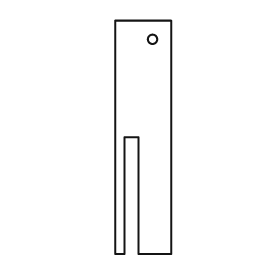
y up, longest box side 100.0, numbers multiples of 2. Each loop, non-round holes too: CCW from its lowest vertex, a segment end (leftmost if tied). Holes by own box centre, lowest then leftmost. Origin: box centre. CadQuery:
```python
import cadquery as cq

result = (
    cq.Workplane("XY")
    .moveTo(-12.0, -50.0)
    .lineTo(-8.0, -50.0)
    .lineTo(-8.0, 0.0)
    .lineTo(-2.0, 0.0)
    .lineTo(-2.0, -50.0)
    .lineTo(12.0, -50.0)
    .lineTo(12.0, 50.0)
    .lineTo(-12.0, 50.0)
    .close()
    .moveTo(4.0, 42.0)
    .circle(2.0)
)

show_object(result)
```